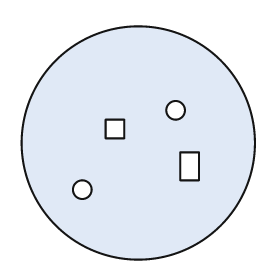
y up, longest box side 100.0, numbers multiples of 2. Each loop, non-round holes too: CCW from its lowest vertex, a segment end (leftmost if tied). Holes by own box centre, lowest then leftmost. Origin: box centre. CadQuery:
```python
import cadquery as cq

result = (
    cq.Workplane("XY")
    .moveTo(0.0, 0.0)
    .circle(50.0)
    .moveTo(-24.0, -20.0)
    .circle(4.0)
    .moveTo(18.0, -16.0)
    .lineTo(26.0, -16.0)
    .lineTo(26.0, -4.0)
    .lineTo(18.0, -4.0)
    .close()
    .moveTo(-14.0, 2.0)
    .lineTo(-6.0, 2.0)
    .lineTo(-6.0, 10.0)
    .lineTo(-14.0, 10.0)
    .close()
    .moveTo(16.0, 14.0)
    .circle(4.0)
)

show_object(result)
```